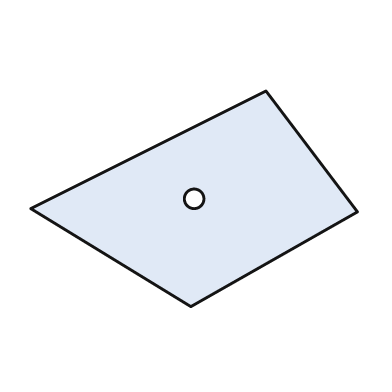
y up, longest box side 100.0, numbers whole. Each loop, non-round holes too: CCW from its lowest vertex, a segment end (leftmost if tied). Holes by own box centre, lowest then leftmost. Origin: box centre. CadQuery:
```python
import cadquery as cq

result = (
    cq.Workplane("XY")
    .moveTo(-1.0, -33.0)
    .lineTo(50.0, -4.0)
    .lineTo(22.0, 33.0)
    .lineTo(-50.0, -3.0)
    .close()
    .moveTo(0.0, 0.0)
    .circle(3.0)
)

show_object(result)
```